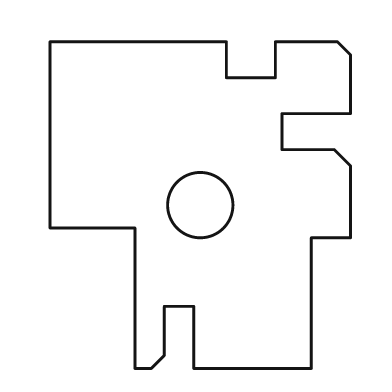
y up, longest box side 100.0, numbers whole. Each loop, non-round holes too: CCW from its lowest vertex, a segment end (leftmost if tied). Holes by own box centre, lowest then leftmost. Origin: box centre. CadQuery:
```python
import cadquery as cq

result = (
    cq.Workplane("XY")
    .moveTo(-20.0, -50.0)
    .lineTo(-15.0, -50.0)
    .lineTo(-11.0, -46.0)
    .lineTo(-11.0, -31.0)
    .lineTo(-2.0, -31.0)
    .lineTo(-2.0, -50.0)
    .lineTo(34.0, -50.0)
    .lineTo(34.0, -10.0)
    .lineTo(46.0, -10.0)
    .lineTo(46.0, 12.0)
    .lineTo(41.0, 17.0)
    .lineTo(25.0, 17.0)
    .lineTo(25.0, 28.0)
    .lineTo(46.0, 28.0)
    .lineTo(46.0, 46.0)
    .lineTo(42.0, 50.0)
    .lineTo(23.0, 50.0)
    .lineTo(23.0, 39.0)
    .lineTo(8.0, 39.0)
    .lineTo(8.0, 50.0)
    .lineTo(-46.0, 50.0)
    .lineTo(-46.0, -7.0)
    .lineTo(-20.0, -7.0)
    .close()
    .moveTo(0.0, 0.0)
    .circle(10.0)
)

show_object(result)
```